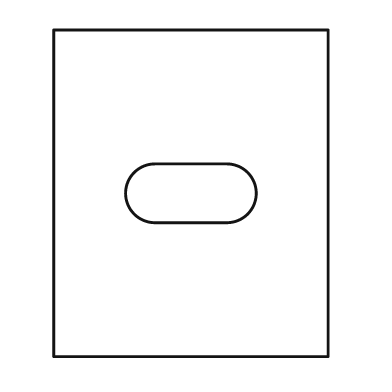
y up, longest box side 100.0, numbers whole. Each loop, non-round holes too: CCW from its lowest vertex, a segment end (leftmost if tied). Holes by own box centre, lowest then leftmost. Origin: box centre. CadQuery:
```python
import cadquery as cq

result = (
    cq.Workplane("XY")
    .moveTo(-42.0, -50.0)
    .lineTo(42.0, -50.0)
    .lineTo(42.0, 50.0)
    .lineTo(-42.0, 50.0)
    .close()
    .moveTo(-11.0, -9.0)
    .lineTo(11.0, -9.0)
    .threePointArc((20.0, 0.0), (11.0, 9.0))
    .lineTo(-11.0, 9.0)
    .threePointArc((-20.0, 0.0), (-11.0, -9.0))
    .close()
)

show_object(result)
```